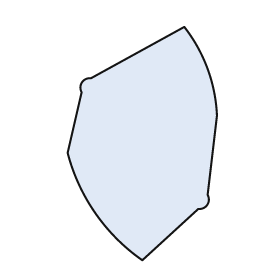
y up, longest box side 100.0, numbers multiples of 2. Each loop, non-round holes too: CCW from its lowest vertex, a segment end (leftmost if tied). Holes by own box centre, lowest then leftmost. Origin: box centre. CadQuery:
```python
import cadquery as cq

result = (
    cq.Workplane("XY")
    .moveTo(0.0, -50.0)
    .lineTo(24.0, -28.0)
    .threePointArc((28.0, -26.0), (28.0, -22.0))
    .lineTo(32.0, 12.0)
    .threePointArc((28.0, 32.0), (18.0, 50.0))
    .lineTo(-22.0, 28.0)
    .threePointArc((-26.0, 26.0), (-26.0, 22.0))
    .lineTo(-32.0, -4.0)
    .threePointArc((-20.0, -30.0), (0.0, -50.0))
    .close()
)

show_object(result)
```